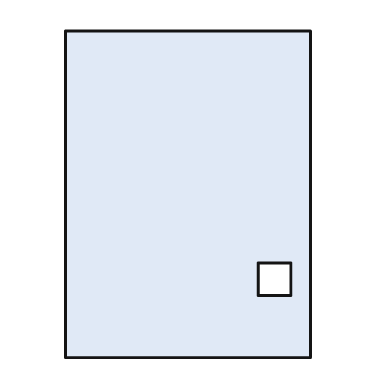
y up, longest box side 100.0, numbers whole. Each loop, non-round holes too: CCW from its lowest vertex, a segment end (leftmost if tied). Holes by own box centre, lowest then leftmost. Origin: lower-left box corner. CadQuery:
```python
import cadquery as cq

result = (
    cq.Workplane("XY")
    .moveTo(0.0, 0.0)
    .lineTo(75.0, 0.0)
    .lineTo(75.0, 100.0)
    .lineTo(0.0, 100.0)
    .close()
    .moveTo(59.0, 19.0)
    .lineTo(69.0, 19.0)
    .lineTo(69.0, 29.0)
    .lineTo(59.0, 29.0)
    .close()
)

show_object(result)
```